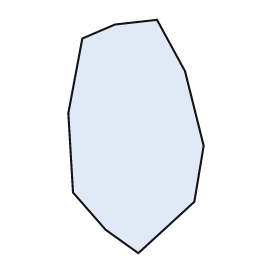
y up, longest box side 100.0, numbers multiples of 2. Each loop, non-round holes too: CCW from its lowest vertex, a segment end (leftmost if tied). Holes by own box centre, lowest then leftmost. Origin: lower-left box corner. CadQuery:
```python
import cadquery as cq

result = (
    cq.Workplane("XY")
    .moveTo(30.0, 0.0)
    .lineTo(54.0, 22.0)
    .lineTo(58.0, 46.0)
    .lineTo(50.0, 78.0)
    .lineTo(38.0, 100.0)
    .lineTo(20.0, 98.0)
    .lineTo(6.0, 92.0)
    .lineTo(0.0, 60.0)
    .lineTo(2.0, 26.0)
    .lineTo(16.0, 10.0)
    .close()
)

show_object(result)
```